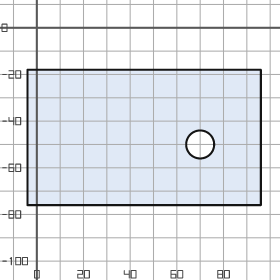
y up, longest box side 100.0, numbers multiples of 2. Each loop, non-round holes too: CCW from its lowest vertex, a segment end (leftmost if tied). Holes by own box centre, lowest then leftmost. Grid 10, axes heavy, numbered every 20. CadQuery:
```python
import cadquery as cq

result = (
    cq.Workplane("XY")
    .moveTo(-4.0, -76.0)
    .lineTo(96.0, -76.0)
    .lineTo(96.0, -18.0)
    .lineTo(-4.0, -18.0)
    .close()
    .moveTo(70.0, -50.0)
    .circle(6.0)
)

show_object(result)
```